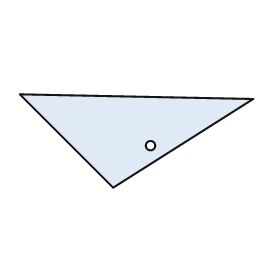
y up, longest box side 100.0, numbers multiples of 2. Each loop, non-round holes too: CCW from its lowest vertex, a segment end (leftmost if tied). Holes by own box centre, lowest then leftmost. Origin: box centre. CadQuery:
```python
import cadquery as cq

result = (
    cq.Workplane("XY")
    .moveTo(-10.0, -20.0)
    .lineTo(50.0, 18.0)
    .lineTo(-50.0, 20.0)
    .close()
    .moveTo(6.0, -2.0)
    .circle(2.0)
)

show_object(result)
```